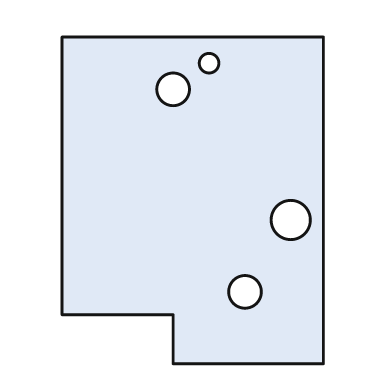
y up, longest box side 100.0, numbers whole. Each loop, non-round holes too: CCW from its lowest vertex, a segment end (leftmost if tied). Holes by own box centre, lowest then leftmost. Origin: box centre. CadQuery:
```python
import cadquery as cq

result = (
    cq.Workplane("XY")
    .moveTo(-6.0, -50.0)
    .lineTo(40.0, -50.0)
    .lineTo(40.0, 50.0)
    .lineTo(-40.0, 50.0)
    .lineTo(-40.0, -35.0)
    .lineTo(-6.0, -35.0)
    .close()
    .moveTo(16.0, -28.0)
    .circle(5.0)
    .moveTo(30.0, -6.0)
    .circle(6.0)
    .moveTo(-6.0, 34.0)
    .circle(5.0)
    .moveTo(5.0, 42.0)
    .circle(3.0)
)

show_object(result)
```